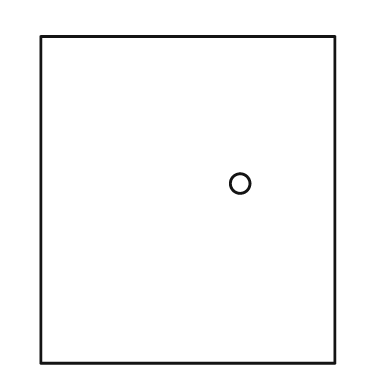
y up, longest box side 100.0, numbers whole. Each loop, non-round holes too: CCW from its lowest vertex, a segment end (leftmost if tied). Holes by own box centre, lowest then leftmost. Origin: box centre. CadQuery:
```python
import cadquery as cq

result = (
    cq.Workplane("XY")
    .moveTo(-45.0, -50.0)
    .lineTo(45.0, -50.0)
    .lineTo(45.0, 50.0)
    .lineTo(-45.0, 50.0)
    .close()
    .moveTo(16.0, 5.0)
    .circle(3.0)
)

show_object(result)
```